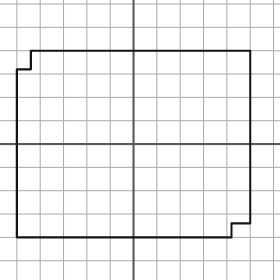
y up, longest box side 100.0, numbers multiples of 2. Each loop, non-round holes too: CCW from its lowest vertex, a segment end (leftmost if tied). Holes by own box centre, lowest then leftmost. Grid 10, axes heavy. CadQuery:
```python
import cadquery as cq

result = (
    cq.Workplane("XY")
    .moveTo(-50.0, -40.0)
    .lineTo(42.0, -40.0)
    .lineTo(42.0, -34.0)
    .lineTo(50.0, -34.0)
    .lineTo(50.0, 40.0)
    .lineTo(-44.0, 40.0)
    .lineTo(-44.0, 32.0)
    .lineTo(-50.0, 32.0)
    .close()
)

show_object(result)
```